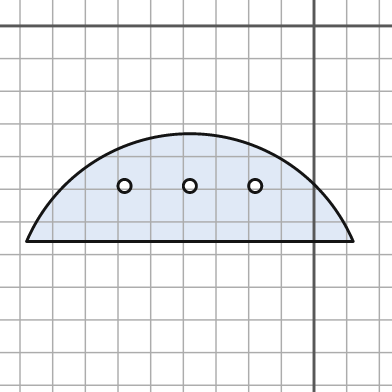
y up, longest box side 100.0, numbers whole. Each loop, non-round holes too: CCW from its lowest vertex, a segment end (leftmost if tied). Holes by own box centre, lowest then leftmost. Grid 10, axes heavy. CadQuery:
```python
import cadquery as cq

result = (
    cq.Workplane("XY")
    .moveTo(-88.0, -66.0)
    .lineTo(12.0, -66.0)
    .threePointArc((-38.0, -33.0), (-88.0, -66.0))
    .close()
    .moveTo(-58.0, -49.0)
    .circle(2.0)
    .moveTo(-38.0, -49.0)
    .circle(2.0)
    .moveTo(-18.0, -49.0)
    .circle(2.0)
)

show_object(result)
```